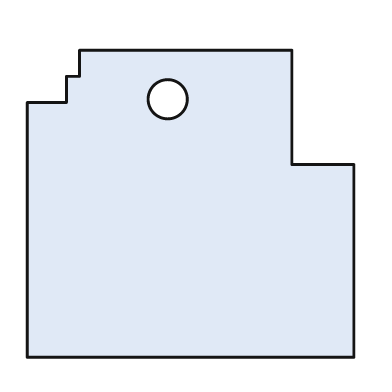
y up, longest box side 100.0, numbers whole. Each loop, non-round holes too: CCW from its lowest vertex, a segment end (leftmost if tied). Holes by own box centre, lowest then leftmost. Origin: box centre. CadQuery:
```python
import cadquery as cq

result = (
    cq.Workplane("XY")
    .moveTo(-50.0, -47.0)
    .lineTo(50.0, -47.0)
    .lineTo(50.0, 12.0)
    .lineTo(31.0, 12.0)
    .lineTo(31.0, 47.0)
    .lineTo(-34.0, 47.0)
    .lineTo(-34.0, 39.0)
    .lineTo(-38.0, 39.0)
    .lineTo(-38.0, 31.0)
    .lineTo(-50.0, 31.0)
    .close()
    .moveTo(-7.0, 32.0)
    .circle(6.0)
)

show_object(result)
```